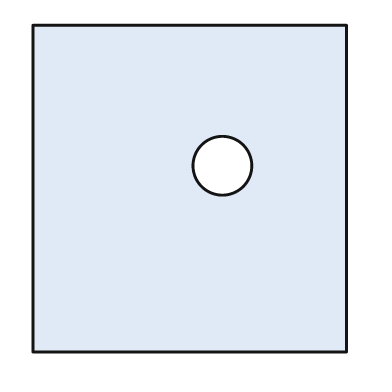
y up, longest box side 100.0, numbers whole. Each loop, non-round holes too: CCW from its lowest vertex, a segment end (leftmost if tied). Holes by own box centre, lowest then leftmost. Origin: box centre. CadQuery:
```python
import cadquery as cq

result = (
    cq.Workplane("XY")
    .moveTo(-48.0, -50.0)
    .lineTo(48.0, -50.0)
    .lineTo(48.0, 50.0)
    .lineTo(-48.0, 50.0)
    .close()
    .moveTo(10.0, 7.0)
    .circle(9.0)
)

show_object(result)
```